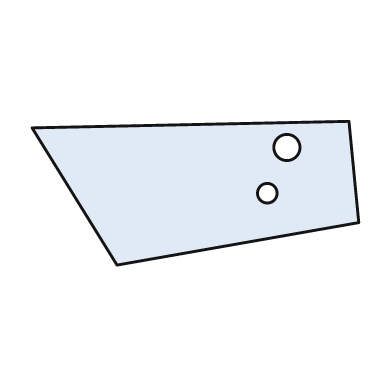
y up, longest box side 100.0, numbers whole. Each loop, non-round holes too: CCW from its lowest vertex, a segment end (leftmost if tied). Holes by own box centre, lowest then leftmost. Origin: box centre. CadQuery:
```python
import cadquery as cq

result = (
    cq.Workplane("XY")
    .moveTo(-24.0, -22.0)
    .lineTo(50.0, -9.0)
    .lineTo(47.0, 22.0)
    .lineTo(-50.0, 20.0)
    .close()
    .moveTo(22.0, 0.0)
    .circle(3.0)
    .moveTo(28.0, 14.0)
    .circle(4.0)
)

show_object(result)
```